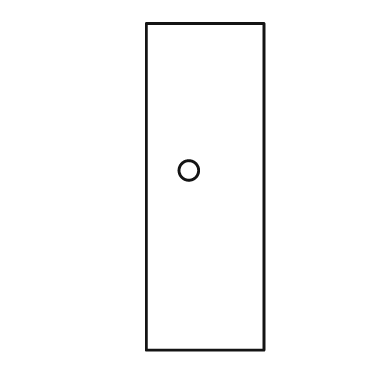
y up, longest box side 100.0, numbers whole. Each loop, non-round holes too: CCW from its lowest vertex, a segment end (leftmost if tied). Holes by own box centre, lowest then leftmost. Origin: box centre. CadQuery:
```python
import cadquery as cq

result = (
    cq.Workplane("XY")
    .moveTo(-18.0, -50.0)
    .lineTo(18.0, -50.0)
    .lineTo(18.0, 50.0)
    .lineTo(-18.0, 50.0)
    .close()
    .moveTo(-5.0, 5.0)
    .circle(3.0)
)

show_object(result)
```